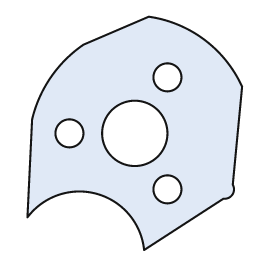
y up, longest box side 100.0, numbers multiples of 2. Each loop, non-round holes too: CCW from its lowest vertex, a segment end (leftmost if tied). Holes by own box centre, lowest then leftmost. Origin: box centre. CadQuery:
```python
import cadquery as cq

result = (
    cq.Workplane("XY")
    .moveTo(4.0, -50.0)
    .lineTo(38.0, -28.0)
    .threePointArc((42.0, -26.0), (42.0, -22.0))
    .lineTo(46.0, 20.0)
    .threePointArc((30.0, 40.0), (6.0, 50.0))
    .lineTo(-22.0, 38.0)
    .threePointArc((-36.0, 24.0), (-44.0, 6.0))
    .lineTo(-46.0, -36.0)
    .threePointArc((-16.0, -26.0), (4.0, -50.0))
    .close()
    .moveTo(14.0, -24.0)
    .circle(6.0)
    .moveTo(-28.0, 0.0)
    .circle(6.0)
    .moveTo(0.0, 0.0)
    .circle(14.0)
    .moveTo(14.0, 24.0)
    .circle(6.0)
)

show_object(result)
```